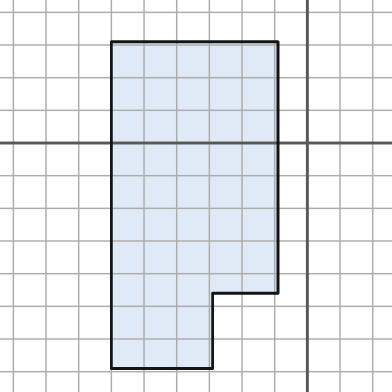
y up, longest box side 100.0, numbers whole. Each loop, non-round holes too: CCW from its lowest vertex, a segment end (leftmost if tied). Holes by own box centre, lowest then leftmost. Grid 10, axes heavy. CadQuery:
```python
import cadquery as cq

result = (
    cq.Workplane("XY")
    .moveTo(-60.0, -69.0)
    .lineTo(-29.0, -69.0)
    .lineTo(-29.0, -46.0)
    .lineTo(-9.0, -46.0)
    .lineTo(-9.0, 31.0)
    .lineTo(-60.0, 31.0)
    .close()
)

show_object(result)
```